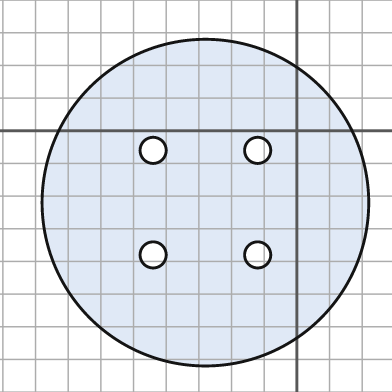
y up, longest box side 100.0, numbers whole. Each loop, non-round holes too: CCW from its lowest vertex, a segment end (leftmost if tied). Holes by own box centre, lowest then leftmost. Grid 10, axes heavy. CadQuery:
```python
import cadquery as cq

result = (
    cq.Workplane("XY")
    .moveTo(-28.0, -22.0)
    .circle(50.0)
    .moveTo(-44.0, -38.0)
    .circle(4.0)
    .moveTo(-12.0, -38.0)
    .circle(4.0)
    .moveTo(-44.0, -6.0)
    .circle(4.0)
    .moveTo(-12.0, -6.0)
    .circle(4.0)
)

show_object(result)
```